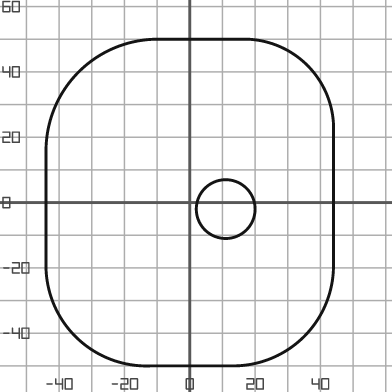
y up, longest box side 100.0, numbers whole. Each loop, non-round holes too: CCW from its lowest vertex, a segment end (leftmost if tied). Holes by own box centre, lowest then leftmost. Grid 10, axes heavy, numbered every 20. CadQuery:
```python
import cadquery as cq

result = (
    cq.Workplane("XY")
    .moveTo(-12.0, -50.0)
    .lineTo(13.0, -50.0)
    .threePointArc((35.0, -41.0), (44.0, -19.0))
    .lineTo(44.0, 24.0)
    .threePointArc((36.0, 42.0), (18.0, 50.0))
    .lineTo(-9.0, 50.0)
    .threePointArc((-34.0, 40.0), (-44.0, 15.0))
    .lineTo(-44.0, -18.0)
    .threePointArc((-35.0, -41.0), (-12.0, -50.0))
    .close()
    .moveTo(11.0, -2.0)
    .circle(9.0)
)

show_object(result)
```